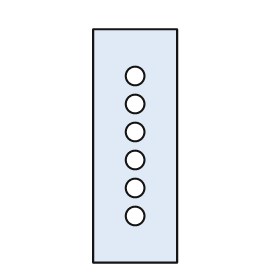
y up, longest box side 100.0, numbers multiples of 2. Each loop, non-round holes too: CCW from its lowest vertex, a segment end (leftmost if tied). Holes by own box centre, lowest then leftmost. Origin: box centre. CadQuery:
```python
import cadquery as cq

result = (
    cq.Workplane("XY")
    .moveTo(-18.0, -50.0)
    .lineTo(18.0, -50.0)
    .lineTo(18.0, 50.0)
    .lineTo(-18.0, 50.0)
    .close()
    .moveTo(0.0, -30.0)
    .circle(4.0)
    .moveTo(0.0, -18.0)
    .circle(4.0)
    .moveTo(0.0, -6.0)
    .circle(4.0)
    .moveTo(0.0, 6.0)
    .circle(4.0)
    .moveTo(0.0, 18.0)
    .circle(4.0)
    .moveTo(0.0, 30.0)
    .circle(4.0)
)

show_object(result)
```